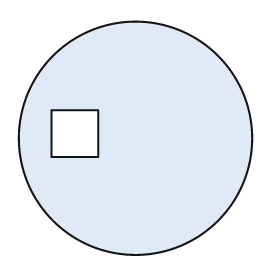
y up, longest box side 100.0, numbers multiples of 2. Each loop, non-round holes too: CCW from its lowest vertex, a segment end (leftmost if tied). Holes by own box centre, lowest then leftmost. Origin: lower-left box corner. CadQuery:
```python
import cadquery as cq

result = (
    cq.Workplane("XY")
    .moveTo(50.0, 50.0)
    .circle(50.0)
    .moveTo(14.0, 42.0)
    .lineTo(34.0, 42.0)
    .lineTo(34.0, 62.0)
    .lineTo(14.0, 62.0)
    .close()
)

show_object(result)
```